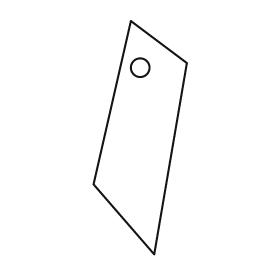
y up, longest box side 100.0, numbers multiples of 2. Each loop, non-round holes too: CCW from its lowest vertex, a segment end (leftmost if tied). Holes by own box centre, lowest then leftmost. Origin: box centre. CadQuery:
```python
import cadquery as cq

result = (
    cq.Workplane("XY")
    .moveTo(6.0, -50.0)
    .lineTo(20.0, 32.0)
    .lineTo(-4.0, 50.0)
    .lineTo(-20.0, -20.0)
    .close()
    .moveTo(0.0, 30.0)
    .circle(4.0)
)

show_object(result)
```